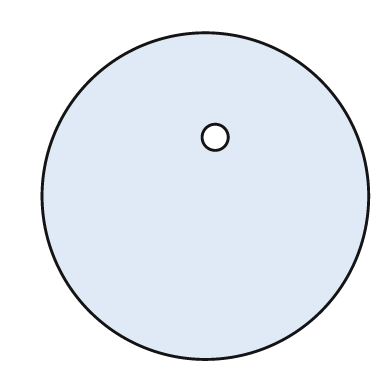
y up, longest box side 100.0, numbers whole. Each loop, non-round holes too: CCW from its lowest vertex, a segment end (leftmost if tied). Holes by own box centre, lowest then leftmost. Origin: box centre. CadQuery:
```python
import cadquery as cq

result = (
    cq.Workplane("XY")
    .moveTo(0.0, 0.0)
    .circle(50.0)
    .moveTo(3.0, 18.0)
    .circle(4.0)
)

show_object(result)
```